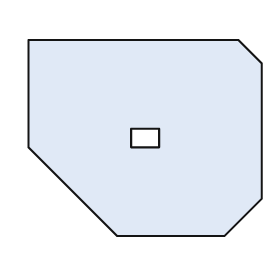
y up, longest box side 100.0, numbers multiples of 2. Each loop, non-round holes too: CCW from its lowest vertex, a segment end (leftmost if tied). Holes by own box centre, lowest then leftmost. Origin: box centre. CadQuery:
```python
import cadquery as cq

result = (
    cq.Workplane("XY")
    .moveTo(-12.0, -42.0)
    .lineTo(34.0, -42.0)
    .lineTo(50.0, -26.0)
    .lineTo(50.0, 32.0)
    .lineTo(40.0, 42.0)
    .lineTo(-50.0, 42.0)
    .lineTo(-50.0, -4.0)
    .close()
    .moveTo(-6.0, -4.0)
    .lineTo(6.0, -4.0)
    .lineTo(6.0, 4.0)
    .lineTo(-6.0, 4.0)
    .close()
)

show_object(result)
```